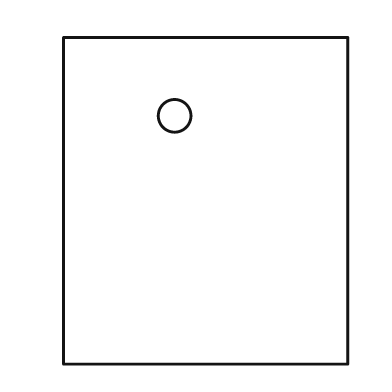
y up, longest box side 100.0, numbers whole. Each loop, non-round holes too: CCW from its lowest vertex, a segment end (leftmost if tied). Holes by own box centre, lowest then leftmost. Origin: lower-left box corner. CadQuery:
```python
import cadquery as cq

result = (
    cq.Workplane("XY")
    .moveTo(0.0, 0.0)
    .lineTo(87.0, 0.0)
    .lineTo(87.0, 100.0)
    .lineTo(0.0, 100.0)
    .close()
    .moveTo(34.0, 76.0)
    .circle(5.0)
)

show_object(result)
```